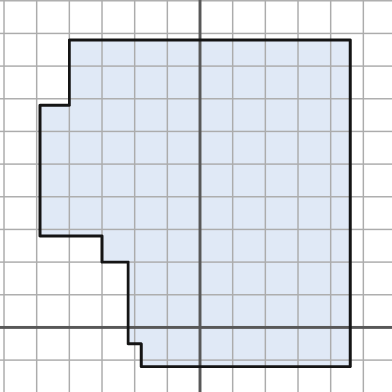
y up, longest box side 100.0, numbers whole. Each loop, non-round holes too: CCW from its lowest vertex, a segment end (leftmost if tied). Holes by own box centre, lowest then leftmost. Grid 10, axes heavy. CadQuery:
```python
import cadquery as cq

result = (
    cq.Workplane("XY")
    .moveTo(-18.0, -12.0)
    .lineTo(46.0, -12.0)
    .lineTo(46.0, 88.0)
    .lineTo(-40.0, 88.0)
    .lineTo(-40.0, 68.0)
    .lineTo(-49.0, 68.0)
    .lineTo(-49.0, 28.0)
    .lineTo(-30.0, 28.0)
    .lineTo(-30.0, 20.0)
    .lineTo(-22.0, 20.0)
    .lineTo(-22.0, -5.0)
    .lineTo(-18.0, -5.0)
    .close()
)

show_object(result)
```